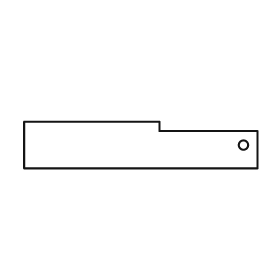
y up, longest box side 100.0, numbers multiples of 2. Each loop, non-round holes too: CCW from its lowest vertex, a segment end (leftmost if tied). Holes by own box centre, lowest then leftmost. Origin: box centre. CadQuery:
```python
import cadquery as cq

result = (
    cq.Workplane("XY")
    .moveTo(-50.0, -10.0)
    .lineTo(50.0, -10.0)
    .lineTo(50.0, 6.0)
    .lineTo(8.0, 6.0)
    .lineTo(8.0, 10.0)
    .lineTo(-50.0, 10.0)
    .close()
    .moveTo(44.0, 0.0)
    .circle(2.0)
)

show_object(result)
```